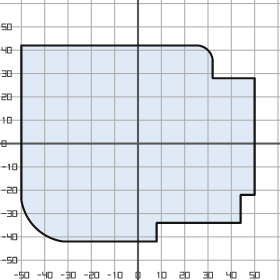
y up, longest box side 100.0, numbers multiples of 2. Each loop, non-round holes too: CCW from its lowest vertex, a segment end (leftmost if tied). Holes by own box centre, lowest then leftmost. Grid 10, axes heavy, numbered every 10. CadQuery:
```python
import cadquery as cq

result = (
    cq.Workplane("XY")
    .moveTo(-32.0, -42.0)
    .lineTo(8.0, -42.0)
    .lineTo(8.0, -34.0)
    .lineTo(44.0, -34.0)
    .lineTo(44.0, -22.0)
    .lineTo(50.0, -22.0)
    .lineTo(50.0, 28.0)
    .lineTo(32.0, 28.0)
    .lineTo(32.0, 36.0)
    .threePointArc((30.0, 40.0), (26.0, 42.0))
    .lineTo(-50.0, 42.0)
    .lineTo(-50.0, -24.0)
    .threePointArc((-44.0, -36.0), (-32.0, -42.0))
    .close()
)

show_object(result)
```